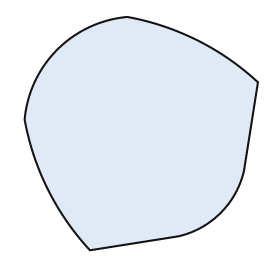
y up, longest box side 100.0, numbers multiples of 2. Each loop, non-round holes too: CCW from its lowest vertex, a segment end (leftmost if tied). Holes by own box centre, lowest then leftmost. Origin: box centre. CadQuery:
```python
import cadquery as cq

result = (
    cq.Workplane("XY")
    .moveTo(-22.0, -50.0)
    .lineTo(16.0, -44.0)
    .threePointArc((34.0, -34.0), (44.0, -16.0))
    .lineTo(50.0, 22.0)
    .threePointArc((24.0, 40.0), (-6.0, 50.0))
    .threePointArc((-36.0, 36.0), (-50.0, 6.0))
    .threePointArc((-40.0, -24.0), (-22.0, -50.0))
    .close()
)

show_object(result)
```